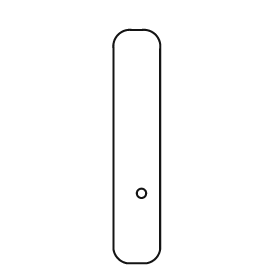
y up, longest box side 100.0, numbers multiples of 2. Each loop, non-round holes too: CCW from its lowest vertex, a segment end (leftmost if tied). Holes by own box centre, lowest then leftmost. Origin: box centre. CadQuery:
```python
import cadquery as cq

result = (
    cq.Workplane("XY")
    .moveTo(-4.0, -50.0)
    .lineTo(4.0, -50.0)
    .threePointArc((8.0, -48.0), (10.0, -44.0))
    .lineTo(10.0, 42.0)
    .threePointArc((8.0, 48.0), (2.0, 50.0))
    .lineTo(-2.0, 50.0)
    .threePointArc((-8.0, 48.0), (-10.0, 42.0))
    .lineTo(-10.0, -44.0)
    .threePointArc((-8.0, -48.0), (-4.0, -50.0))
    .close()
    .moveTo(2.0, -20.0)
    .circle(2.0)
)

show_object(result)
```